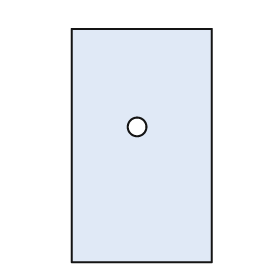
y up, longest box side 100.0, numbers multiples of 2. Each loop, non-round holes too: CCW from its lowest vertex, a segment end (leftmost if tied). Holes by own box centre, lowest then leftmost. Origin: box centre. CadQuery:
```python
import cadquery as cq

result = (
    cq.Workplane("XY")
    .moveTo(-30.0, -50.0)
    .lineTo(30.0, -50.0)
    .lineTo(30.0, 50.0)
    .lineTo(-30.0, 50.0)
    .close()
    .moveTo(-2.0, 8.0)
    .circle(4.0)
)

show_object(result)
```